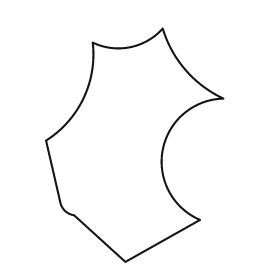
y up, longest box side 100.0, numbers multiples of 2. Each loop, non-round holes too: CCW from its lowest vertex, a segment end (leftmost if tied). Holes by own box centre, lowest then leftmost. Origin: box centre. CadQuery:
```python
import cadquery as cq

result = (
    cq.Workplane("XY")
    .moveTo(-4.0, -50.0)
    .lineTo(28.0, -32.0)
    .threePointArc((12.0, -2.0), (38.0, 20.0))
    .threePointArc((22.0, 32.0), (12.0, 50.0))
    .threePointArc((-2.0, 42.0), (-18.0, 44.0))
    .threePointArc((-22.0, 20.0), (-38.0, 2.0))
    .lineTo(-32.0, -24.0)
    .threePointArc((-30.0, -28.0), (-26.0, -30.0))
    .close()
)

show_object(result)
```